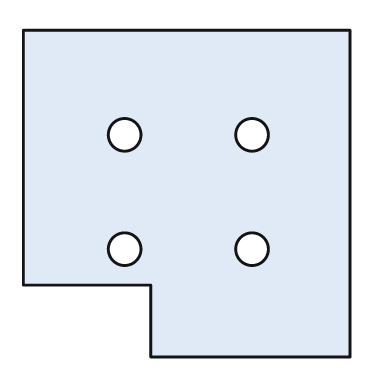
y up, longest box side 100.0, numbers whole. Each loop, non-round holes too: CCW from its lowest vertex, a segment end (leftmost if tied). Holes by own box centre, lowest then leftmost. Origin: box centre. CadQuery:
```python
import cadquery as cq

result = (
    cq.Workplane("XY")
    .moveTo(-11.0, -50.0)
    .lineTo(50.0, -50.0)
    .lineTo(50.0, 50.0)
    .lineTo(-50.0, 50.0)
    .lineTo(-50.0, -28.0)
    .lineTo(-11.0, -28.0)
    .close()
    .moveTo(-19.0, -17.0)
    .circle(5.0)
    .moveTo(20.0, -17.0)
    .circle(5.0)
    .moveTo(-19.0, 18.0)
    .circle(5.0)
    .moveTo(20.0, 18.0)
    .circle(5.0)
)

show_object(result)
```